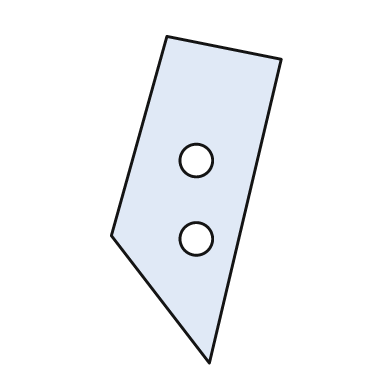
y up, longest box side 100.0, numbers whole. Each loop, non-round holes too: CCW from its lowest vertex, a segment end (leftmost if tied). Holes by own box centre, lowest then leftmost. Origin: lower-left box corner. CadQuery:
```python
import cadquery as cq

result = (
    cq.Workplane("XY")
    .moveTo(30.0, 0.0)
    .lineTo(52.0, 93.0)
    .lineTo(17.0, 100.0)
    .lineTo(0.0, 39.0)
    .close()
    .moveTo(26.0, 38.0)
    .circle(5.0)
    .moveTo(26.0, 62.0)
    .circle(5.0)
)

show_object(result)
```